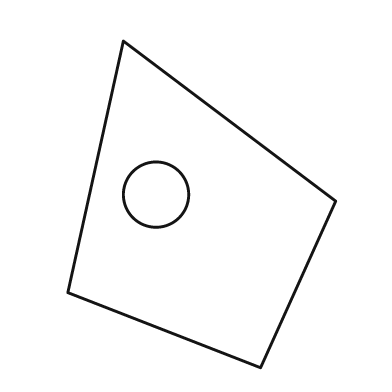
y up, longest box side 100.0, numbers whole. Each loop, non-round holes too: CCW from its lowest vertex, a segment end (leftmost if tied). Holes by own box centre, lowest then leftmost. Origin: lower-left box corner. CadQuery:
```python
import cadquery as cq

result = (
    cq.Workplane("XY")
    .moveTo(59.0, 0.0)
    .lineTo(82.0, 51.0)
    .lineTo(17.0, 100.0)
    .lineTo(0.0, 23.0)
    .close()
    .moveTo(27.0, 53.0)
    .circle(10.0)
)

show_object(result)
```